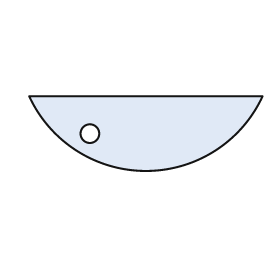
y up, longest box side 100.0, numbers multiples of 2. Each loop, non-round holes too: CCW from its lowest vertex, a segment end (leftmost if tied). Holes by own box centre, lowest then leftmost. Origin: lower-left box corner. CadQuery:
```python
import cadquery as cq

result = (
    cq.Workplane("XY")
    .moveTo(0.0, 32.0)
    .threePointArc((50.0, 0.0), (100.0, 32.0))
    .close()
    .moveTo(26.0, 16.0)
    .circle(4.0)
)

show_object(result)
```